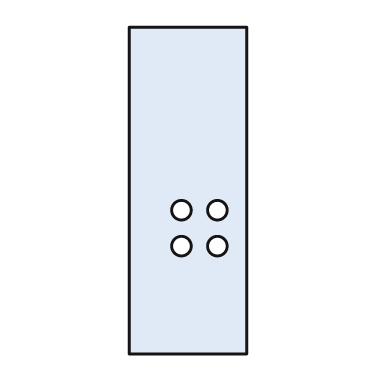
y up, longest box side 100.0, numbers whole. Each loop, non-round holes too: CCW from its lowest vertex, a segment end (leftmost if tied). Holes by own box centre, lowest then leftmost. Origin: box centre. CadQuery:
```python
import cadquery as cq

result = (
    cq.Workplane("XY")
    .moveTo(-18.0, -50.0)
    .lineTo(18.0, -50.0)
    .lineTo(18.0, 50.0)
    .lineTo(-18.0, 50.0)
    .close()
    .moveTo(-2.0, -17.0)
    .circle(3.0)
    .moveTo(9.0, -17.0)
    .circle(3.0)
    .moveTo(-2.0, -6.0)
    .circle(3.0)
    .moveTo(9.0, -6.0)
    .circle(3.0)
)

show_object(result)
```